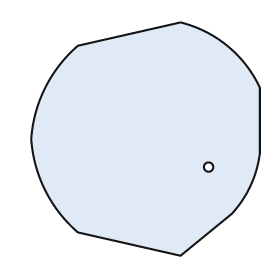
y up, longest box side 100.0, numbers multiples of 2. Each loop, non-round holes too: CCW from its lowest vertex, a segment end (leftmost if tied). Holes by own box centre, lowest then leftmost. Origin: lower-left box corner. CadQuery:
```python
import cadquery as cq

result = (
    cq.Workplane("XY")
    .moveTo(64.0, 0.0)
    .lineTo(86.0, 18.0)
    .threePointArc((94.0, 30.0), (98.0, 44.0))
    .lineTo(98.0, 72.0)
    .threePointArc((84.0, 90.0), (64.0, 100.0))
    .lineTo(20.0, 90.0)
    .threePointArc((6.0, 72.0), (0.0, 50.0))
    .threePointArc((6.0, 28.0), (20.0, 10.0))
    .close()
    .moveTo(76.0, 38.0)
    .circle(2.0)
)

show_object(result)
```